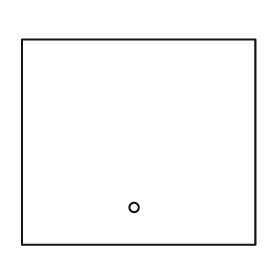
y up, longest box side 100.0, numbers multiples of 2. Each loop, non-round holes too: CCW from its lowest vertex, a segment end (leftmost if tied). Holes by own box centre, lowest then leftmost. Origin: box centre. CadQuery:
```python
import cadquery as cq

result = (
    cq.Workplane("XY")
    .moveTo(-50.0, -44.0)
    .lineTo(50.0, -44.0)
    .lineTo(50.0, 44.0)
    .lineTo(-50.0, 44.0)
    .close()
    .moveTo(-2.0, -28.0)
    .circle(2.0)
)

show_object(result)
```